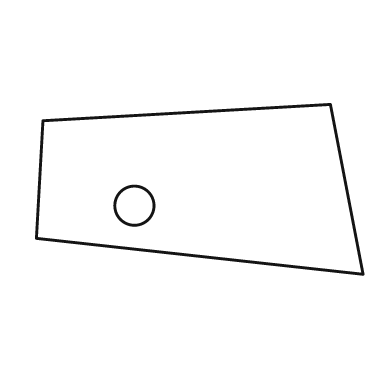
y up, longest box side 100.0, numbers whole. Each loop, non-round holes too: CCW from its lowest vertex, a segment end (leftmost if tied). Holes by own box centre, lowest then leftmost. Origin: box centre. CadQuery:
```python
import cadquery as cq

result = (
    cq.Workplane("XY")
    .moveTo(50.0, -26.0)
    .lineTo(40.0, 26.0)
    .lineTo(-48.0, 21.0)
    .lineTo(-50.0, -15.0)
    .close()
    .moveTo(-20.0, -5.0)
    .circle(6.0)
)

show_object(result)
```